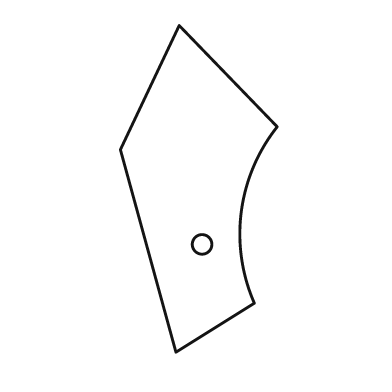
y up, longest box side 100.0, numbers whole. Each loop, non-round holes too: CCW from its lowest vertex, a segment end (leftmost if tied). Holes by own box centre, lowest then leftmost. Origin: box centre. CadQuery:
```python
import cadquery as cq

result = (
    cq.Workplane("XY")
    .moveTo(-7.0, -50.0)
    .lineTo(17.0, -35.0)
    .threePointArc((13.0, -7.0), (24.0, 19.0))
    .lineTo(-6.0, 50.0)
    .lineTo(-24.0, 12.0)
    .close()
    .moveTo(1.0, -17.0)
    .circle(3.0)
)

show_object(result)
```